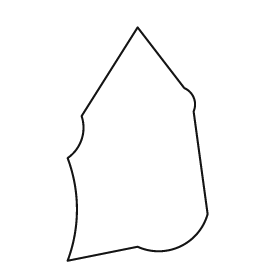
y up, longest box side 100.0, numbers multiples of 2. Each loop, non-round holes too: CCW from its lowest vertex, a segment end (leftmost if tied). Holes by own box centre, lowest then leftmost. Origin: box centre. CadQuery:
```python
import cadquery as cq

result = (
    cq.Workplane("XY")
    .moveTo(-30.0, -50.0)
    .lineTo(0.0, -44.0)
    .threePointArc((18.0, -44.0), (30.0, -30.0))
    .lineTo(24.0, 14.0)
    .threePointArc((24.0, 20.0), (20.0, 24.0))
    .lineTo(0.0, 50.0)
    .lineTo(-24.0, 12.0)
    .threePointArc((-24.0, 2.0), (-30.0, -6.0))
    .threePointArc((-26.0, -28.0), (-30.0, -50.0))
    .close()
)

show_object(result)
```